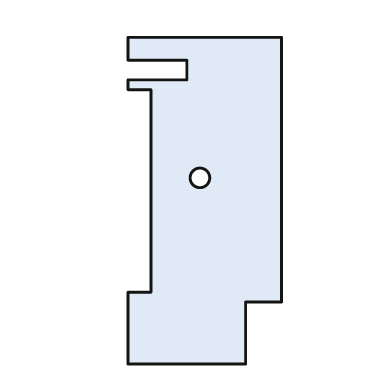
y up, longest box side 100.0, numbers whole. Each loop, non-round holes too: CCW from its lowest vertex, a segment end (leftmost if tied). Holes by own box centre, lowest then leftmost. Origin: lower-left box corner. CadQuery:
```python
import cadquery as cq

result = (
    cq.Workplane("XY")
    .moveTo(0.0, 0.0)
    .lineTo(36.0, 0.0)
    .lineTo(36.0, 19.0)
    .lineTo(47.0, 19.0)
    .lineTo(47.0, 100.0)
    .lineTo(0.0, 100.0)
    .lineTo(0.0, 93.0)
    .lineTo(18.0, 93.0)
    .lineTo(18.0, 87.0)
    .lineTo(0.0, 87.0)
    .lineTo(0.0, 84.0)
    .lineTo(7.0, 84.0)
    .lineTo(7.0, 22.0)
    .lineTo(0.0, 22.0)
    .close()
    .moveTo(22.0, 57.0)
    .circle(3.0)
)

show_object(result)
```